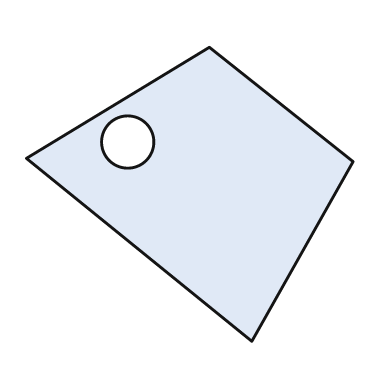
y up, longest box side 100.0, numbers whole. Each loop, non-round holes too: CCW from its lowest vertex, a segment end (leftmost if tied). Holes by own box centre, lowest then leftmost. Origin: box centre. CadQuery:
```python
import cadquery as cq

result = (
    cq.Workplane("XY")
    .moveTo(19.0, -45.0)
    .lineTo(50.0, 10.0)
    .lineTo(6.0, 45.0)
    .lineTo(-50.0, 11.0)
    .close()
    .moveTo(-19.0, 16.0)
    .circle(8.0)
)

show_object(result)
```